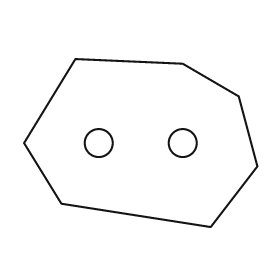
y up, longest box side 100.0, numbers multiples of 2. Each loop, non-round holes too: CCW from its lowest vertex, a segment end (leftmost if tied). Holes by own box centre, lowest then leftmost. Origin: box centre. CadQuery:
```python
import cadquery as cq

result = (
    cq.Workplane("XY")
    .moveTo(30.0, -36.0)
    .lineTo(50.0, -10.0)
    .lineTo(42.0, 20.0)
    .lineTo(18.0, 34.0)
    .lineTo(-28.0, 36.0)
    .lineTo(-50.0, 0.0)
    .lineTo(-34.0, -26.0)
    .close()
    .moveTo(-18.0, 0.0)
    .circle(6.0)
    .moveTo(18.0, 0.0)
    .circle(6.0)
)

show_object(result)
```